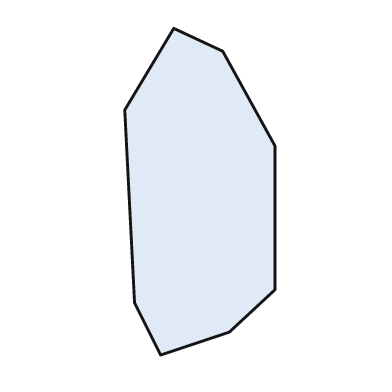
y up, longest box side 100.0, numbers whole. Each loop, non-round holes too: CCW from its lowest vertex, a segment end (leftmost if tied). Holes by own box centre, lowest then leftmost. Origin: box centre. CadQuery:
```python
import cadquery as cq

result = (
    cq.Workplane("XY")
    .moveTo(-12.0, -50.0)
    .lineTo(9.0, -43.0)
    .lineTo(23.0, -30.0)
    .lineTo(23.0, 14.0)
    .lineTo(7.0, 43.0)
    .lineTo(-8.0, 50.0)
    .lineTo(-23.0, 25.0)
    .lineTo(-20.0, -34.0)
    .close()
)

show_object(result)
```